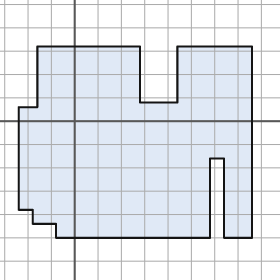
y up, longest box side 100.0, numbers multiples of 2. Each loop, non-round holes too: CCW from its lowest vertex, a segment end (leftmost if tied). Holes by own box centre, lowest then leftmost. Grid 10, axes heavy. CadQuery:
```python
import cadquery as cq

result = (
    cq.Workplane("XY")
    .moveTo(-8.0, -50.0)
    .lineTo(58.0, -50.0)
    .lineTo(58.0, -16.0)
    .lineTo(64.0, -16.0)
    .lineTo(64.0, -50.0)
    .lineTo(76.0, -50.0)
    .lineTo(76.0, 32.0)
    .lineTo(44.0, 32.0)
    .lineTo(44.0, 8.0)
    .lineTo(28.0, 8.0)
    .lineTo(28.0, 32.0)
    .lineTo(-16.0, 32.0)
    .lineTo(-16.0, 6.0)
    .lineTo(-24.0, 6.0)
    .lineTo(-24.0, -38.0)
    .lineTo(-18.0, -38.0)
    .lineTo(-18.0, -44.0)
    .lineTo(-8.0, -44.0)
    .close()
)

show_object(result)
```